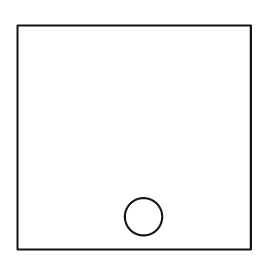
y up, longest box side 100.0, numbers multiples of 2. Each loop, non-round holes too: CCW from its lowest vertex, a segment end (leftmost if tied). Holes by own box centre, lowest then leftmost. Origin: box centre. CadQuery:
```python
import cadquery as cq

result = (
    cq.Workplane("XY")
    .moveTo(-50.0, -48.0)
    .lineTo(50.0, -48.0)
    .lineTo(50.0, 48.0)
    .lineTo(-50.0, 48.0)
    .close()
    .moveTo(4.0, -34.0)
    .circle(8.0)
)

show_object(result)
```